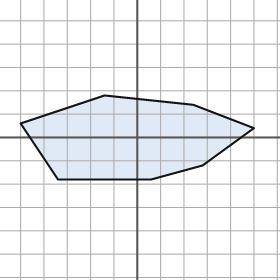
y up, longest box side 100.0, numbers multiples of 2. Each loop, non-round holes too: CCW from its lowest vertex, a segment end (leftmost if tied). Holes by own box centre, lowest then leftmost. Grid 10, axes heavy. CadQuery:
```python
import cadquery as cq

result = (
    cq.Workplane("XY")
    .moveTo(-34.0, -18.0)
    .lineTo(6.0, -18.0)
    .lineTo(28.0, -12.0)
    .lineTo(50.0, 4.0)
    .lineTo(24.0, 14.0)
    .lineTo(-14.0, 18.0)
    .lineTo(-50.0, 6.0)
    .close()
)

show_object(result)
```